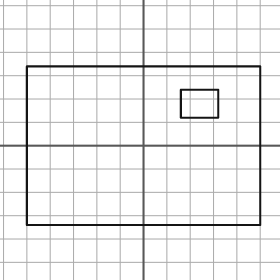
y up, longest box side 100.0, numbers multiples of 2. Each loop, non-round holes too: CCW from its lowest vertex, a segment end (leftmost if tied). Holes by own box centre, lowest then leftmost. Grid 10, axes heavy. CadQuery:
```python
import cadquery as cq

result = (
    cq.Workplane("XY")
    .moveTo(-50.0, -34.0)
    .lineTo(50.0, -34.0)
    .lineTo(50.0, 34.0)
    .lineTo(-50.0, 34.0)
    .close()
    .moveTo(16.0, 12.0)
    .lineTo(32.0, 12.0)
    .lineTo(32.0, 24.0)
    .lineTo(16.0, 24.0)
    .close()
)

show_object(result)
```